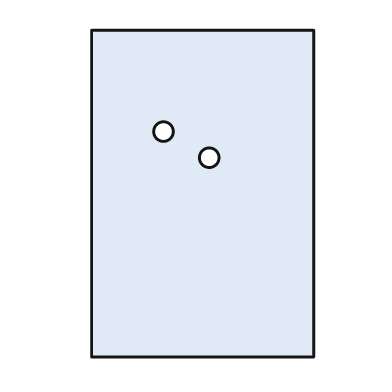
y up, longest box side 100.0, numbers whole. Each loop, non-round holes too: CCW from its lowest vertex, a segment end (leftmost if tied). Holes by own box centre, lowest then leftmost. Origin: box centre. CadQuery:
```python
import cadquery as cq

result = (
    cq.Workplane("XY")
    .moveTo(-34.0, -50.0)
    .lineTo(34.0, -50.0)
    .lineTo(34.0, 50.0)
    .lineTo(-34.0, 50.0)
    .close()
    .moveTo(2.0, 11.0)
    .circle(3.0)
    .moveTo(-12.0, 19.0)
    .circle(3.0)
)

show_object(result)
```